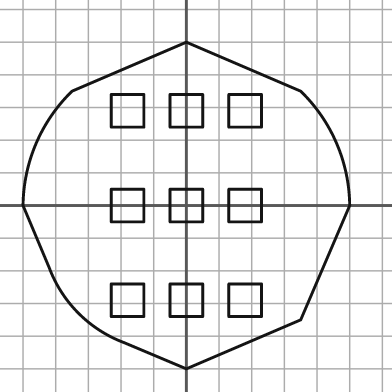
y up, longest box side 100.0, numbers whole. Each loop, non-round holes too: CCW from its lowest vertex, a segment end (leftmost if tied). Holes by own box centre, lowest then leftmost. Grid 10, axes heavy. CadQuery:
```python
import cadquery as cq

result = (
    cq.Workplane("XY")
    .moveTo(0.0, -50.0)
    .lineTo(35.0, -35.0)
    .lineTo(50.0, 0.0)
    .threePointArc((46.0, 19.0), (35.0, 35.0))
    .lineTo(0.0, 50.0)
    .lineTo(-35.0, 35.0)
    .threePointArc((-46.0, 19.0), (-50.0, 0.0))
    .lineTo(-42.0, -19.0)
    .threePointArc((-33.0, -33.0), (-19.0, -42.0))
    .close()
    .moveTo(-23.0, -34.0)
    .lineTo(-13.0, -34.0)
    .lineTo(-13.0, -24.0)
    .lineTo(-23.0, -24.0)
    .close()
    .moveTo(-5.0, -34.0)
    .lineTo(5.0, -34.0)
    .lineTo(5.0, -24.0)
    .lineTo(-5.0, -24.0)
    .close()
    .moveTo(13.0, -34.0)
    .lineTo(23.0, -34.0)
    .lineTo(23.0, -24.0)
    .lineTo(13.0, -24.0)
    .close()
    .moveTo(-23.0, -5.0)
    .lineTo(-13.0, -5.0)
    .lineTo(-13.0, 5.0)
    .lineTo(-23.0, 5.0)
    .close()
    .moveTo(-5.0, -5.0)
    .lineTo(5.0, -5.0)
    .lineTo(5.0, 5.0)
    .lineTo(-5.0, 5.0)
    .close()
    .moveTo(13.0, -5.0)
    .lineTo(23.0, -5.0)
    .lineTo(23.0, 5.0)
    .lineTo(13.0, 5.0)
    .close()
    .moveTo(-23.0, 24.0)
    .lineTo(-13.0, 24.0)
    .lineTo(-13.0, 34.0)
    .lineTo(-23.0, 34.0)
    .close()
    .moveTo(-5.0, 24.0)
    .lineTo(5.0, 24.0)
    .lineTo(5.0, 34.0)
    .lineTo(-5.0, 34.0)
    .close()
    .moveTo(13.0, 24.0)
    .lineTo(23.0, 24.0)
    .lineTo(23.0, 34.0)
    .lineTo(13.0, 34.0)
    .close()
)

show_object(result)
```